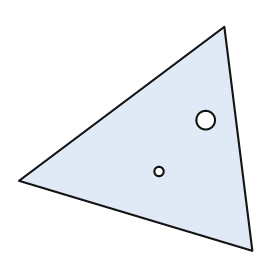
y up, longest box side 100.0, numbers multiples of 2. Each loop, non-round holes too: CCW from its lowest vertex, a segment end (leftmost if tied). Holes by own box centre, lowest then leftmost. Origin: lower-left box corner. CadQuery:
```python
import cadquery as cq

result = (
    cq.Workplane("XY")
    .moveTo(100.0, 0.0)
    .lineTo(88.0, 96.0)
    .lineTo(0.0, 30.0)
    .close()
    .moveTo(60.0, 34.0)
    .circle(2.0)
    .moveTo(80.0, 56.0)
    .circle(4.0)
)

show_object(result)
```